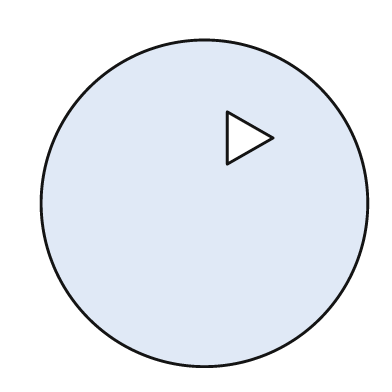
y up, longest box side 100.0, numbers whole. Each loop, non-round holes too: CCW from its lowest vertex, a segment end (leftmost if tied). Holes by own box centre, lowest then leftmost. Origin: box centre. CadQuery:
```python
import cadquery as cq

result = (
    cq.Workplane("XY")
    .moveTo(0.0, 0.0)
    .circle(50.0)
    .moveTo(7.0, 12.0)
    .lineTo(21.0, 20.0)
    .lineTo(7.0, 28.0)
    .close()
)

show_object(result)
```